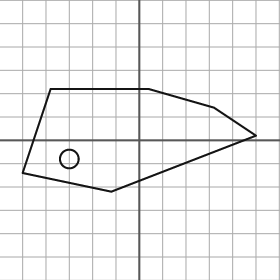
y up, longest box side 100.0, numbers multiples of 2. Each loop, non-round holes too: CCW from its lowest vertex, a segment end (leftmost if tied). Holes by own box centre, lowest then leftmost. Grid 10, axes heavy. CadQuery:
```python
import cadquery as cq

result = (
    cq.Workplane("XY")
    .moveTo(-12.0, -22.0)
    .lineTo(50.0, 2.0)
    .lineTo(32.0, 14.0)
    .lineTo(4.0, 22.0)
    .lineTo(-38.0, 22.0)
    .lineTo(-50.0, -14.0)
    .close()
    .moveTo(-30.0, -8.0)
    .circle(4.0)
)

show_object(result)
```